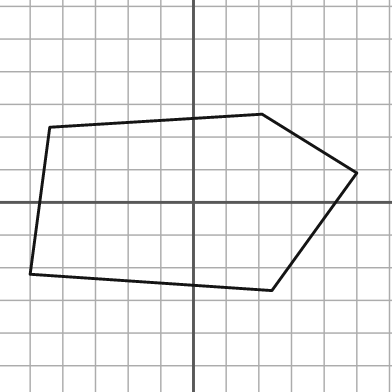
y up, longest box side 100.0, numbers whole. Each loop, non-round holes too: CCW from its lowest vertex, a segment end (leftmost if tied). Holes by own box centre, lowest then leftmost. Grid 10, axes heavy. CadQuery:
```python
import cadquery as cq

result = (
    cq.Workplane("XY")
    .moveTo(24.0, -27.0)
    .lineTo(50.0, 9.0)
    .lineTo(21.0, 27.0)
    .lineTo(-44.0, 23.0)
    .lineTo(-50.0, -22.0)
    .close()
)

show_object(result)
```